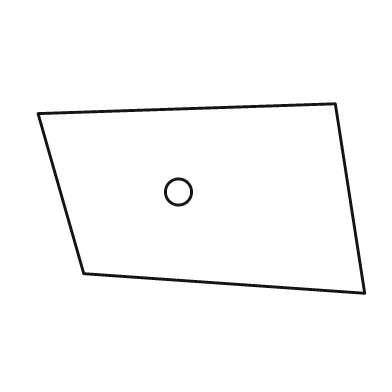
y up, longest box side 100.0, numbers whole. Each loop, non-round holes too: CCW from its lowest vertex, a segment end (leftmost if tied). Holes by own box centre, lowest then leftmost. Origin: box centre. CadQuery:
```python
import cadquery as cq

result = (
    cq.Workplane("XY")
    .moveTo(50.0, -29.0)
    .lineTo(41.0, 29.0)
    .lineTo(-50.0, 26.0)
    .lineTo(-36.0, -23.0)
    .close()
    .moveTo(-7.0, 2.0)
    .circle(4.0)
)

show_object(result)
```